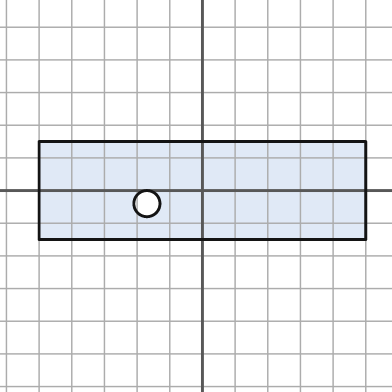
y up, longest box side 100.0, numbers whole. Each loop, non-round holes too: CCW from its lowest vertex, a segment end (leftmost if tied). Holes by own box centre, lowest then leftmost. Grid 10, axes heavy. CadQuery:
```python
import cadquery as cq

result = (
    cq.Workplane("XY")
    .moveTo(-50.0, -15.0)
    .lineTo(50.0, -15.0)
    .lineTo(50.0, 15.0)
    .lineTo(-50.0, 15.0)
    .close()
    .moveTo(-17.0, -4.0)
    .circle(4.0)
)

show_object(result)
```